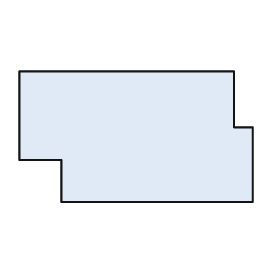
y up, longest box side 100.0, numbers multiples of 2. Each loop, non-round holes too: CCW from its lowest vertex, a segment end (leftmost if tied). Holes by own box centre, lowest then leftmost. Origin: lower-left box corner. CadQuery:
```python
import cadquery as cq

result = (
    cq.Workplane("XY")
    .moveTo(18.0, 0.0)
    .lineTo(100.0, 0.0)
    .lineTo(100.0, 32.0)
    .lineTo(92.0, 32.0)
    .lineTo(92.0, 56.0)
    .lineTo(0.0, 56.0)
    .lineTo(0.0, 18.0)
    .lineTo(18.0, 18.0)
    .close()
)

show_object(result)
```